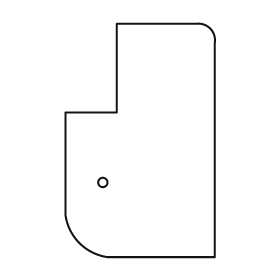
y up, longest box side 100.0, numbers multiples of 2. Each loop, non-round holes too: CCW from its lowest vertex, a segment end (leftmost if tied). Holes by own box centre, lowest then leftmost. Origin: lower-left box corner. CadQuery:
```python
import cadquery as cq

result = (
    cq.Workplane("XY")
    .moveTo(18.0, 0.0)
    .lineTo(64.0, 0.0)
    .lineTo(64.0, 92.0)
    .threePointArc((62.0, 98.0), (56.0, 100.0))
    .lineTo(22.0, 100.0)
    .lineTo(22.0, 62.0)
    .lineTo(0.0, 62.0)
    .lineTo(0.0, 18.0)
    .threePointArc((6.0, 6.0), (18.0, 0.0))
    .close()
    .moveTo(16.0, 32.0)
    .circle(2.0)
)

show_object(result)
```